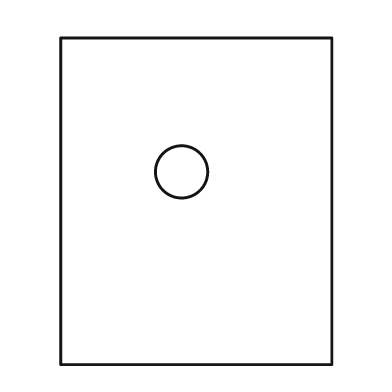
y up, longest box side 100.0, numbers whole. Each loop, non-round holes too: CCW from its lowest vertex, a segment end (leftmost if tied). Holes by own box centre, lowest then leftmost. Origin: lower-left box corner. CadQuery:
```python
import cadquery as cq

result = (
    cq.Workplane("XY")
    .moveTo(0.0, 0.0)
    .lineTo(83.0, 0.0)
    .lineTo(83.0, 100.0)
    .lineTo(0.0, 100.0)
    .close()
    .moveTo(37.0, 59.0)
    .circle(8.0)
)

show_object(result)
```